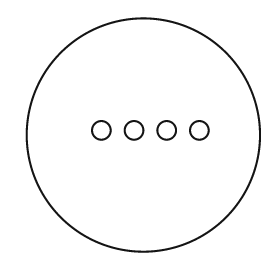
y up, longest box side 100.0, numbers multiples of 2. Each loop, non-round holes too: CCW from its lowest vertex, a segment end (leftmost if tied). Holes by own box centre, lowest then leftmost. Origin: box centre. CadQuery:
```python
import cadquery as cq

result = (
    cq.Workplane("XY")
    .moveTo(0.0, 0.0)
    .circle(50.0)
    .moveTo(-18.0, 2.0)
    .circle(4.0)
    .moveTo(-4.0, 2.0)
    .circle(4.0)
    .moveTo(10.0, 2.0)
    .circle(4.0)
    .moveTo(24.0, 2.0)
    .circle(4.0)
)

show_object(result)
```